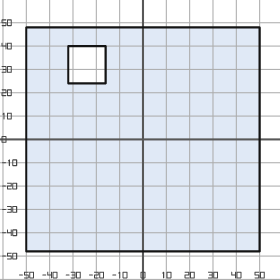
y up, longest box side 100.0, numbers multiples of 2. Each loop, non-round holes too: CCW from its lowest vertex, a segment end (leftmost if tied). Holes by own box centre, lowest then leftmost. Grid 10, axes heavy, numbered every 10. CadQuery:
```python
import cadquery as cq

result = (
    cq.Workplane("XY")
    .moveTo(-50.0, -48.0)
    .lineTo(50.0, -48.0)
    .lineTo(50.0, 48.0)
    .lineTo(-50.0, 48.0)
    .close()
    .moveTo(-32.0, 24.0)
    .lineTo(-16.0, 24.0)
    .lineTo(-16.0, 40.0)
    .lineTo(-32.0, 40.0)
    .close()
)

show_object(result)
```